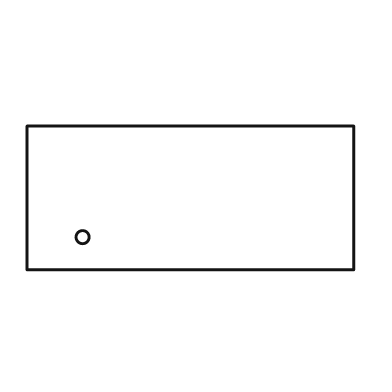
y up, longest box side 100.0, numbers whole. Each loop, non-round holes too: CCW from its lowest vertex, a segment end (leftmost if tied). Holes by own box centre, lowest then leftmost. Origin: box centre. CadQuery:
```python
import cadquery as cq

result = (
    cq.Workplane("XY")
    .moveTo(-50.0, -22.0)
    .lineTo(50.0, -22.0)
    .lineTo(50.0, 22.0)
    .lineTo(-50.0, 22.0)
    .close()
    .moveTo(-33.0, -12.0)
    .circle(2.0)
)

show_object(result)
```